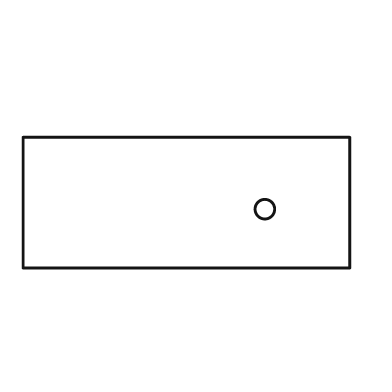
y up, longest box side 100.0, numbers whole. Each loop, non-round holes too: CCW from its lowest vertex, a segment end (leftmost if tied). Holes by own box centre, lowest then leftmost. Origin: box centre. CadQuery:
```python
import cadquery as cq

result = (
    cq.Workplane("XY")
    .moveTo(-50.0, -20.0)
    .lineTo(50.0, -20.0)
    .lineTo(50.0, 20.0)
    .lineTo(-50.0, 20.0)
    .close()
    .moveTo(24.0, -2.0)
    .circle(3.0)
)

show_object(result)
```